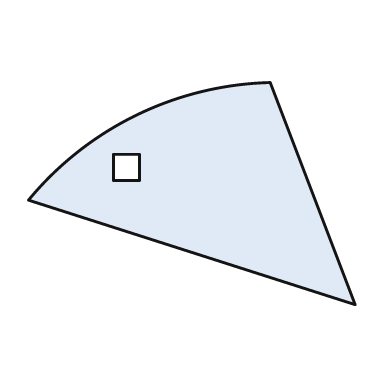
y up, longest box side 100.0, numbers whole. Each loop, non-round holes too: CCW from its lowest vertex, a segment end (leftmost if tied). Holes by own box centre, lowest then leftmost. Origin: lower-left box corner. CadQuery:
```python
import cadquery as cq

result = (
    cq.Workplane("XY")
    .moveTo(100.0, 0.0)
    .lineTo(74.0, 68.0)
    .threePointArc((33.0, 58.0), (0.0, 32.0))
    .close()
    .moveTo(26.0, 38.0)
    .lineTo(34.0, 38.0)
    .lineTo(34.0, 46.0)
    .lineTo(26.0, 46.0)
    .close()
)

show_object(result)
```